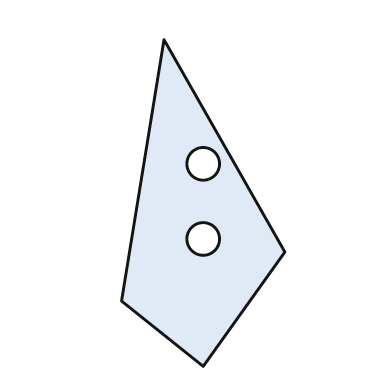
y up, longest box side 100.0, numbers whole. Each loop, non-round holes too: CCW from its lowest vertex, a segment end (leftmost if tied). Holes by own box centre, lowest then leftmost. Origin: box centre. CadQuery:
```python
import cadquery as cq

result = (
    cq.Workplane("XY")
    .moveTo(0.0, -50.0)
    .lineTo(25.0, -15.0)
    .lineTo(-12.0, 50.0)
    .lineTo(-25.0, -30.0)
    .close()
    .moveTo(0.0, -11.0)
    .circle(5.0)
    .moveTo(0.0, 12.0)
    .circle(5.0)
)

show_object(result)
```